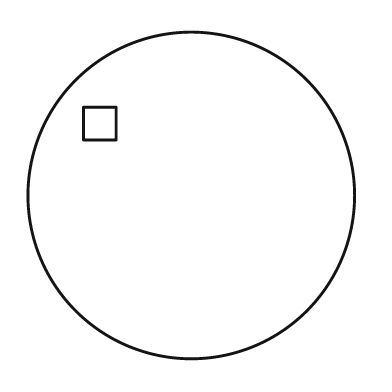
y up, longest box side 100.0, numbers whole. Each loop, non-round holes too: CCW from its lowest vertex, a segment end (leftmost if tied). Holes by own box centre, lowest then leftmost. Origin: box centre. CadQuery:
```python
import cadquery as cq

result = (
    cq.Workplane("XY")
    .moveTo(0.0, 0.0)
    .circle(50.0)
    .moveTo(-33.0, 17.0)
    .lineTo(-23.0, 17.0)
    .lineTo(-23.0, 27.0)
    .lineTo(-33.0, 27.0)
    .close()
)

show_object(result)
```